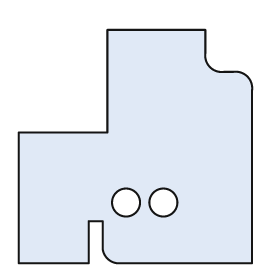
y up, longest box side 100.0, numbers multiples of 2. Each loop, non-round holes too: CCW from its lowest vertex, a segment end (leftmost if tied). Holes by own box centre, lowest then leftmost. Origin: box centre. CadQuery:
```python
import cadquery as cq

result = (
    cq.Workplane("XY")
    .moveTo(-50.0, -50.0)
    .lineTo(-20.0, -50.0)
    .lineTo(-20.0, -32.0)
    .lineTo(-14.0, -32.0)
    .lineTo(-14.0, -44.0)
    .threePointArc((-12.0, -48.0), (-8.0, -50.0))
    .lineTo(50.0, -50.0)
    .lineTo(50.0, 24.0)
    .threePointArc((48.0, 30.0), (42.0, 32.0))
    .lineTo(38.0, 32.0)
    .threePointArc((32.0, 34.0), (30.0, 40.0))
    .lineTo(30.0, 50.0)
    .lineTo(-12.0, 50.0)
    .lineTo(-12.0, 6.0)
    .lineTo(-50.0, 6.0)
    .close()
    .moveTo(-4.0, -24.0)
    .circle(6.0)
    .moveTo(12.0, -24.0)
    .circle(6.0)
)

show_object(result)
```